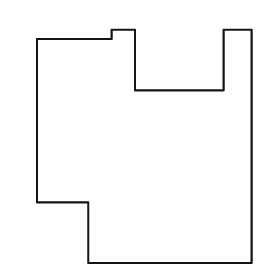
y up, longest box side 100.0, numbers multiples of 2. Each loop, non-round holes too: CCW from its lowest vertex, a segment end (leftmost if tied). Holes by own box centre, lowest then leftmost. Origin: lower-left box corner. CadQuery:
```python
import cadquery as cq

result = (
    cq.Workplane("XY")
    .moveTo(22.0, 0.0)
    .lineTo(92.0, 0.0)
    .lineTo(92.0, 100.0)
    .lineTo(80.0, 100.0)
    .lineTo(80.0, 74.0)
    .lineTo(42.0, 74.0)
    .lineTo(42.0, 100.0)
    .lineTo(32.0, 100.0)
    .lineTo(32.0, 96.0)
    .lineTo(0.0, 96.0)
    .lineTo(0.0, 26.0)
    .lineTo(22.0, 26.0)
    .close()
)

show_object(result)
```